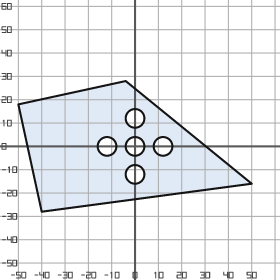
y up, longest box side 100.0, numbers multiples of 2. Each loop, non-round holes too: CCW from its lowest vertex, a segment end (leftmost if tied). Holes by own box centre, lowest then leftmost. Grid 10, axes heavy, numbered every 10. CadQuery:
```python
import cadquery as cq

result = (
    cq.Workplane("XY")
    .moveTo(-40.0, -28.0)
    .lineTo(50.0, -16.0)
    .lineTo(-4.0, 28.0)
    .lineTo(-50.0, 18.0)
    .close()
    .moveTo(0.0, -12.0)
    .circle(4.0)
    .moveTo(-12.0, 0.0)
    .circle(4.0)
    .moveTo(0.0, 0.0)
    .circle(4.0)
    .moveTo(12.0, 0.0)
    .circle(4.0)
    .moveTo(0.0, 12.0)
    .circle(4.0)
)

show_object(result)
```